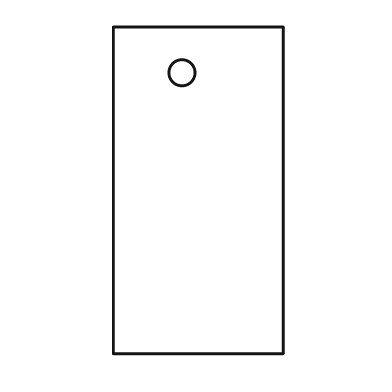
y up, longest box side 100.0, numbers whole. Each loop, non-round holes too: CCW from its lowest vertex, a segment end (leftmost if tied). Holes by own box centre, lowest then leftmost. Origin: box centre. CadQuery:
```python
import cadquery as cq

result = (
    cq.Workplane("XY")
    .moveTo(-26.0, -50.0)
    .lineTo(26.0, -50.0)
    .lineTo(26.0, 50.0)
    .lineTo(-26.0, 50.0)
    .close()
    .moveTo(-5.0, 36.0)
    .circle(4.0)
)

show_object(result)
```